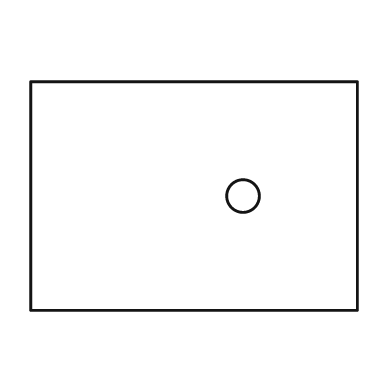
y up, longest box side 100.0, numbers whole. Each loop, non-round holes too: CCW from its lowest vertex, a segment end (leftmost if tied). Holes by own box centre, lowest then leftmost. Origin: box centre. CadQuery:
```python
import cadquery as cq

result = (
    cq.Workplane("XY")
    .moveTo(-50.0, -35.0)
    .lineTo(50.0, -35.0)
    .lineTo(50.0, 35.0)
    .lineTo(-50.0, 35.0)
    .close()
    .moveTo(15.0, 0.0)
    .circle(5.0)
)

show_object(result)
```